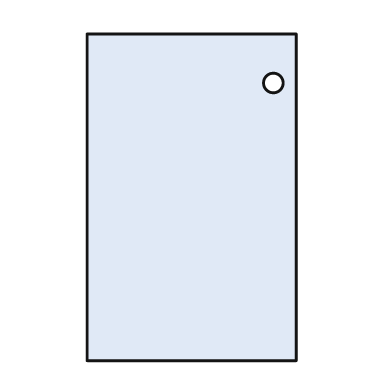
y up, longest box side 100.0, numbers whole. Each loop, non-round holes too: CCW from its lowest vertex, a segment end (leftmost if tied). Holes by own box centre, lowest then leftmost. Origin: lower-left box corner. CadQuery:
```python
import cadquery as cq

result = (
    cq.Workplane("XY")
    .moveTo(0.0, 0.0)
    .lineTo(64.0, 0.0)
    .lineTo(64.0, 100.0)
    .lineTo(0.0, 100.0)
    .close()
    .moveTo(57.0, 85.0)
    .circle(3.0)
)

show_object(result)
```